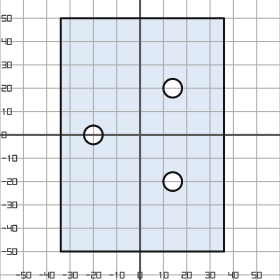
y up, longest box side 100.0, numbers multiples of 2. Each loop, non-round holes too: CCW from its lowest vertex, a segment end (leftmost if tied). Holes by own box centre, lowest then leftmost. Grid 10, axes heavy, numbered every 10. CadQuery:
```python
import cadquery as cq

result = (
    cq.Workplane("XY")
    .moveTo(-34.0, -50.0)
    .lineTo(36.0, -50.0)
    .lineTo(36.0, 50.0)
    .lineTo(-34.0, 50.0)
    .close()
    .moveTo(14.0, -20.0)
    .circle(4.0)
    .moveTo(-20.0, 0.0)
    .circle(4.0)
    .moveTo(14.0, 20.0)
    .circle(4.0)
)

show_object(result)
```